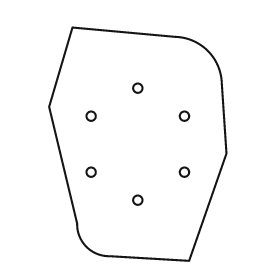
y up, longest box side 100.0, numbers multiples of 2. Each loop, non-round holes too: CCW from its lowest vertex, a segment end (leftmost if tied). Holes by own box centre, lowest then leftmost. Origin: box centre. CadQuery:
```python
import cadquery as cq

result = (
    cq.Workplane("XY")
    .moveTo(22.0, -50.0)
    .lineTo(38.0, -4.0)
    .lineTo(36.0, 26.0)
    .threePointArc((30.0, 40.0), (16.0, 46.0))
    .lineTo(-28.0, 50.0)
    .lineTo(-38.0, 16.0)
    .lineTo(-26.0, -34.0)
    .threePointArc((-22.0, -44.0), (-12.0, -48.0))
    .close()
    .moveTo(0.0, -24.0)
    .circle(2.0)
    .moveTo(-20.0, -12.0)
    .circle(2.0)
    .moveTo(20.0, -12.0)
    .circle(2.0)
    .moveTo(-20.0, 12.0)
    .circle(2.0)
    .moveTo(20.0, 12.0)
    .circle(2.0)
    .moveTo(0.0, 24.0)
    .circle(2.0)
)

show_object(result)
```